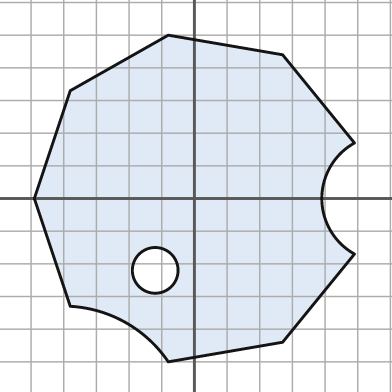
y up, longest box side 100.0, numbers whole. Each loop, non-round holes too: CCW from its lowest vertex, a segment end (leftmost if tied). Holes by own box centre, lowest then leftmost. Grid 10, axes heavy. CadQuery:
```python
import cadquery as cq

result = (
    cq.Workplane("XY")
    .moveTo(-8.0, -50.0)
    .lineTo(27.0, -44.0)
    .lineTo(49.0, -17.0)
    .threePointArc((39.0, 0.0), (49.0, 17.0))
    .lineTo(27.0, 44.0)
    .lineTo(-8.0, 50.0)
    .lineTo(-38.0, 33.0)
    .lineTo(-49.0, 0.0)
    .lineTo(-38.0, -33.0)
    .threePointArc((-21.0, -38.0), (-8.0, -50.0))
    .close()
    .moveTo(-12.0, -22.0)
    .circle(7.0)
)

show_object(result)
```